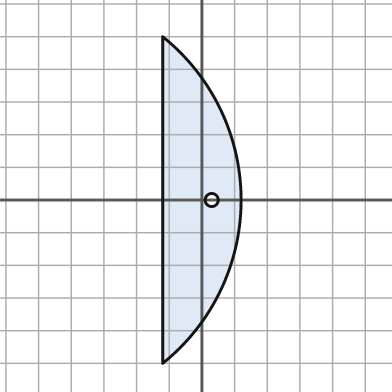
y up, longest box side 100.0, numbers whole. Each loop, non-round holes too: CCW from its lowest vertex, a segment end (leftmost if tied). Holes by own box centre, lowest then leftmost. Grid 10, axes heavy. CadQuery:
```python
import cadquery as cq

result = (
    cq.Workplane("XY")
    .moveTo(-12.0, -50.0)
    .threePointArc((12.0, 0.0), (-12.0, 50.0))
    .close()
    .moveTo(3.0, 0.0)
    .circle(2.0)
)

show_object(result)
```